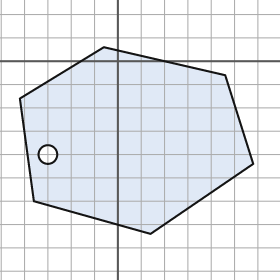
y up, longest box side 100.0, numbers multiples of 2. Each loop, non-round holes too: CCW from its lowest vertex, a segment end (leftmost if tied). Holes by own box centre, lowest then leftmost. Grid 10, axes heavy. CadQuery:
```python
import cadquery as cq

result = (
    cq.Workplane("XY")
    .moveTo(14.0, -74.0)
    .lineTo(58.0, -44.0)
    .lineTo(46.0, -6.0)
    .lineTo(-6.0, 6.0)
    .lineTo(-42.0, -16.0)
    .lineTo(-36.0, -60.0)
    .close()
    .moveTo(-30.0, -40.0)
    .circle(4.0)
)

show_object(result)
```